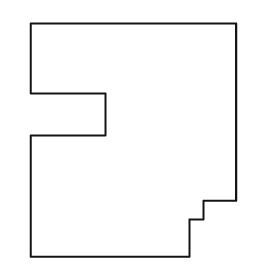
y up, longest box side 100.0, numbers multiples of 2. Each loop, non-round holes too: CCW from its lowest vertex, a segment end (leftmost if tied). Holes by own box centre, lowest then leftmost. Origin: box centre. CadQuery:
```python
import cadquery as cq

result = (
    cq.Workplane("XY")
    .moveTo(-44.0, -50.0)
    .lineTo(24.0, -50.0)
    .lineTo(24.0, -34.0)
    .lineTo(30.0, -34.0)
    .lineTo(30.0, -26.0)
    .lineTo(44.0, -26.0)
    .lineTo(44.0, 50.0)
    .lineTo(-44.0, 50.0)
    .lineTo(-44.0, 20.0)
    .lineTo(-12.0, 20.0)
    .lineTo(-12.0, 2.0)
    .lineTo(-44.0, 2.0)
    .close()
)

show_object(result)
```